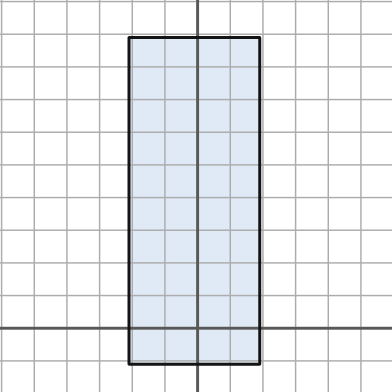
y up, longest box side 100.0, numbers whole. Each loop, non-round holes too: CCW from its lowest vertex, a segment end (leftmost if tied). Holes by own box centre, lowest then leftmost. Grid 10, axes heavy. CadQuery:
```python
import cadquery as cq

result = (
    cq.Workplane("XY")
    .moveTo(-21.0, -11.0)
    .lineTo(19.0, -11.0)
    .lineTo(19.0, 89.0)
    .lineTo(-21.0, 89.0)
    .close()
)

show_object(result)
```